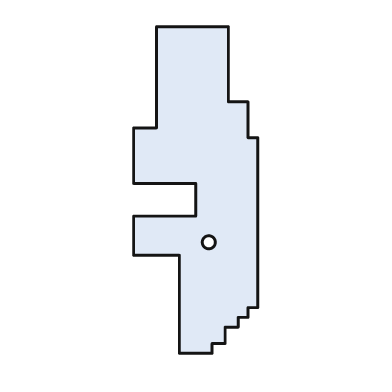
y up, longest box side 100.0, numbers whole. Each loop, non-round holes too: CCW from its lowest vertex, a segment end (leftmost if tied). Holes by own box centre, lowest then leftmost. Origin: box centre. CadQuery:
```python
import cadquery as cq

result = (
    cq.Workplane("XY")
    .moveTo(-5.0, -50.0)
    .lineTo(5.0, -50.0)
    .lineTo(5.0, -47.0)
    .lineTo(9.0, -47.0)
    .lineTo(9.0, -42.0)
    .lineTo(13.0, -42.0)
    .lineTo(13.0, -39.0)
    .lineTo(16.0, -39.0)
    .lineTo(16.0, -36.0)
    .lineTo(19.0, -36.0)
    .lineTo(19.0, 16.0)
    .lineTo(16.0, 16.0)
    .lineTo(16.0, 27.0)
    .lineTo(10.0, 27.0)
    .lineTo(10.0, 50.0)
    .lineTo(-12.0, 50.0)
    .lineTo(-12.0, 19.0)
    .lineTo(-19.0, 19.0)
    .lineTo(-19.0, 2.0)
    .lineTo(0.0, 2.0)
    .lineTo(0.0, -8.0)
    .lineTo(-19.0, -8.0)
    .lineTo(-19.0, -20.0)
    .lineTo(-5.0, -20.0)
    .close()
    .moveTo(4.0, -16.0)
    .circle(2.0)
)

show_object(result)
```